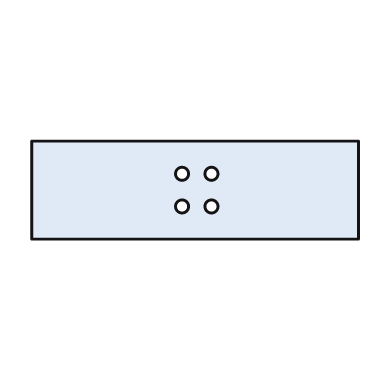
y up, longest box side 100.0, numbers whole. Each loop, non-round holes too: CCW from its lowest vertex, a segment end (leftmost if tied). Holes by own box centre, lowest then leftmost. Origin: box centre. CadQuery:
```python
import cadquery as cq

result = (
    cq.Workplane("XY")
    .moveTo(-50.0, -15.0)
    .lineTo(50.0, -15.0)
    .lineTo(50.0, 15.0)
    .lineTo(-50.0, 15.0)
    .close()
    .moveTo(-4.0, -5.0)
    .circle(2.0)
    .moveTo(5.0, -5.0)
    .circle(2.0)
    .moveTo(-4.0, 5.0)
    .circle(2.0)
    .moveTo(5.0, 5.0)
    .circle(2.0)
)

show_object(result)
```